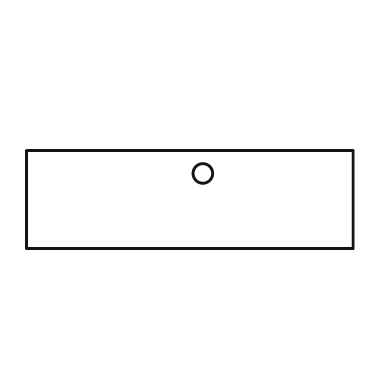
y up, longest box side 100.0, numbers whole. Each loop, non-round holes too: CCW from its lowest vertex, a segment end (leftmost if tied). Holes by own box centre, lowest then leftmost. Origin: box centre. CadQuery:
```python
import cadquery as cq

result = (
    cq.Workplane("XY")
    .moveTo(-50.0, -15.0)
    .lineTo(50.0, -15.0)
    .lineTo(50.0, 15.0)
    .lineTo(-50.0, 15.0)
    .close()
    .moveTo(4.0, 8.0)
    .circle(3.0)
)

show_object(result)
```